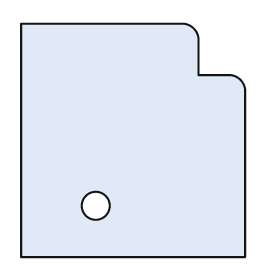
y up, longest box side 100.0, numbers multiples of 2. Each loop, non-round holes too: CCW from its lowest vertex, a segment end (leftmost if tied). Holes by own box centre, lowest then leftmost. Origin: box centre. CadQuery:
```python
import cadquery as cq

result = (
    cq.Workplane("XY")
    .moveTo(-48.0, -50.0)
    .lineTo(48.0, -50.0)
    .lineTo(48.0, 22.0)
    .threePointArc((46.0, 26.0), (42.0, 28.0))
    .lineTo(28.0, 28.0)
    .lineTo(28.0, 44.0)
    .threePointArc((26.0, 48.0), (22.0, 50.0))
    .lineTo(-48.0, 50.0)
    .close()
    .moveTo(-16.0, -28.0)
    .circle(6.0)
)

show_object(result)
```